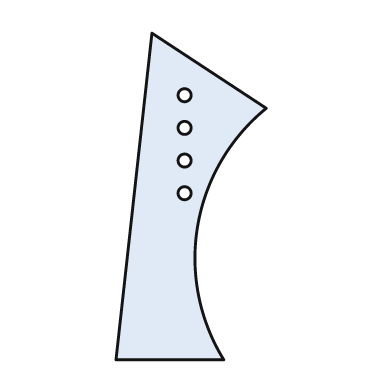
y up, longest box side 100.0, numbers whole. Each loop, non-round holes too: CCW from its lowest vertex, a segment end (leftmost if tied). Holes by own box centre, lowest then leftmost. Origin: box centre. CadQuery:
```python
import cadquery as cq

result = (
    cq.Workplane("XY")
    .moveTo(-23.0, -50.0)
    .lineTo(10.0, -50.0)
    .threePointArc((2.0, -9.0), (23.0, 27.0))
    .lineTo(-12.0, 50.0)
    .close()
    .moveTo(-2.0, 1.0)
    .circle(2.0)
    .moveTo(-2.0, 11.0)
    .circle(2.0)
    .moveTo(-2.0, 21.0)
    .circle(2.0)
    .moveTo(-2.0, 31.0)
    .circle(2.0)
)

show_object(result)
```